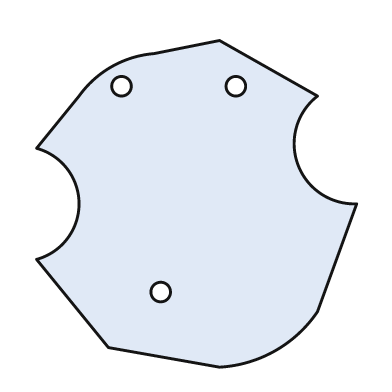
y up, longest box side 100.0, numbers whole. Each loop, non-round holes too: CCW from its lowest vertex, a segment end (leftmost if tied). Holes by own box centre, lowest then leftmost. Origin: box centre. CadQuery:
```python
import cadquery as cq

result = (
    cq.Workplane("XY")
    .moveTo(7.0, -50.0)
    .threePointArc((24.0, -45.0), (37.0, -33.0))
    .lineTo(49.0, 0.0)
    .threePointArc((31.0, 12.0), (37.0, 33.0))
    .lineTo(7.0, 50.0)
    .lineTo(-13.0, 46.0)
    .threePointArc((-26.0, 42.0), (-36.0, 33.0))
    .lineTo(-49.0, 17.0)
    .threePointArc((-36.0, 0.0), (-49.0, -17.0))
    .lineTo(-27.0, -44.0)
    .close()
    .moveTo(-11.0, -27.0)
    .circle(3.0)
    .moveTo(-23.0, 36.0)
    .circle(3.0)
    .moveTo(12.0, 36.0)
    .circle(3.0)
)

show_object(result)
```